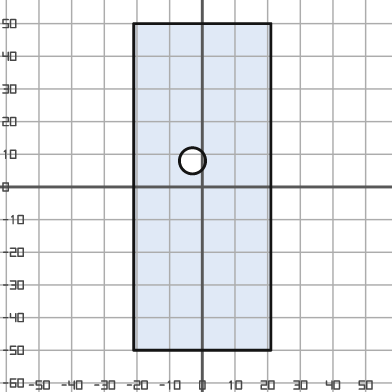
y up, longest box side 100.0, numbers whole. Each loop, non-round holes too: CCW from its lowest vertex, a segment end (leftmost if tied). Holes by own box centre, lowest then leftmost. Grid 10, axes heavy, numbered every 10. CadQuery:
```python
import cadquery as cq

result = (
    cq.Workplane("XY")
    .moveTo(-21.0, -50.0)
    .lineTo(21.0, -50.0)
    .lineTo(21.0, 50.0)
    .lineTo(-21.0, 50.0)
    .close()
    .moveTo(-3.0, 8.0)
    .circle(4.0)
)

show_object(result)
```